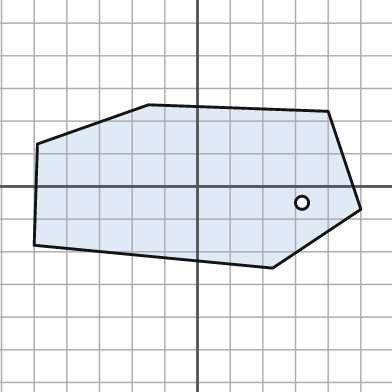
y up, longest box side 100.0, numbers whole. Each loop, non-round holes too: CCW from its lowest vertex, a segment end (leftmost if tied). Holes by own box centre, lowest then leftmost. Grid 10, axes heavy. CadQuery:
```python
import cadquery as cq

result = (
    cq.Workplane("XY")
    .moveTo(23.0, -25.0)
    .lineTo(50.0, -7.0)
    .lineTo(40.0, 23.0)
    .lineTo(-15.0, 25.0)
    .lineTo(-49.0, 13.0)
    .lineTo(-50.0, -18.0)
    .close()
    .moveTo(32.0, -5.0)
    .circle(2.0)
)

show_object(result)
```